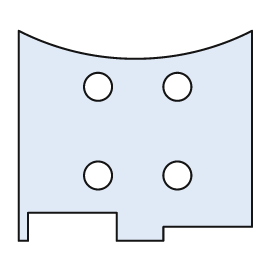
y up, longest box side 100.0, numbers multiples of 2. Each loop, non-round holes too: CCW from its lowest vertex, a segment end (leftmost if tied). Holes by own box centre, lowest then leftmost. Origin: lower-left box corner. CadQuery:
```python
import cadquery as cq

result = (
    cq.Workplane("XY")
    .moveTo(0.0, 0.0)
    .lineTo(4.0, 0.0)
    .lineTo(4.0, 12.0)
    .lineTo(42.0, 12.0)
    .lineTo(42.0, 0.0)
    .lineTo(62.0, 0.0)
    .lineTo(62.0, 6.0)
    .lineTo(100.0, 6.0)
    .lineTo(100.0, 90.0)
    .threePointArc((50.0, 78.0), (0.0, 90.0))
    .close()
    .moveTo(34.0, 28.0)
    .circle(6.0)
    .moveTo(68.0, 28.0)
    .circle(6.0)
    .moveTo(34.0, 66.0)
    .circle(6.0)
    .moveTo(68.0, 66.0)
    .circle(6.0)
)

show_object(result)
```